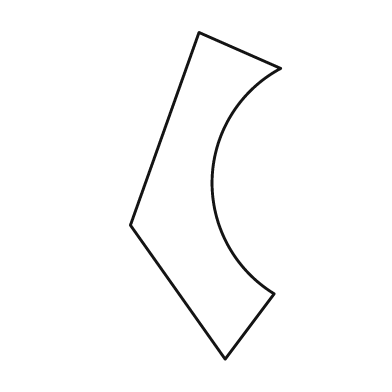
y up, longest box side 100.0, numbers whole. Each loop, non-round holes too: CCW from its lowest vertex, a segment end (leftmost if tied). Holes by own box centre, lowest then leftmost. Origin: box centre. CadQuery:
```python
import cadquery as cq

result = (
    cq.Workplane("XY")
    .moveTo(6.0, -50.0)
    .lineTo(21.0, -30.0)
    .threePointArc((2.0, 5.0), (23.0, 39.0))
    .lineTo(-2.0, 50.0)
    .lineTo(-23.0, -9.0)
    .close()
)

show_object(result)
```